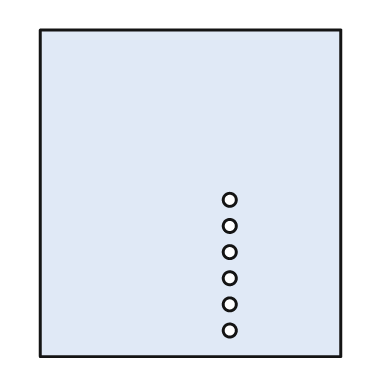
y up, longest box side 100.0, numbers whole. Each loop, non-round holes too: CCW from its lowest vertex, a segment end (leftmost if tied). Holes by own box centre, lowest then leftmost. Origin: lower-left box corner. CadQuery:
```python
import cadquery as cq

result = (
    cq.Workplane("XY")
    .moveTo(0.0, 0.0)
    .lineTo(92.0, 0.0)
    .lineTo(92.0, 100.0)
    .lineTo(0.0, 100.0)
    .close()
    .moveTo(58.0, 8.0)
    .circle(2.0)
    .moveTo(58.0, 16.0)
    .circle(2.0)
    .moveTo(58.0, 24.0)
    .circle(2.0)
    .moveTo(58.0, 32.0)
    .circle(2.0)
    .moveTo(58.0, 40.0)
    .circle(2.0)
    .moveTo(58.0, 48.0)
    .circle(2.0)
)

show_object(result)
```